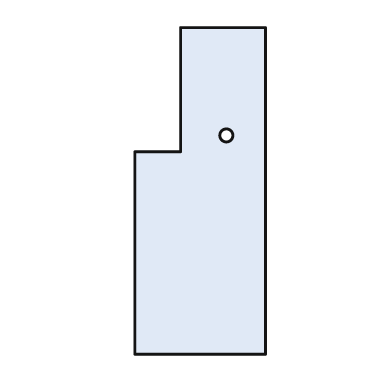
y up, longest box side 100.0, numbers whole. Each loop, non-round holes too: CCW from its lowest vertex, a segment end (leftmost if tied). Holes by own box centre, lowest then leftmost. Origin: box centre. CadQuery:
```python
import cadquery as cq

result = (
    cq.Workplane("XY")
    .moveTo(-20.0, -50.0)
    .lineTo(20.0, -50.0)
    .lineTo(20.0, 50.0)
    .lineTo(-6.0, 50.0)
    .lineTo(-6.0, 12.0)
    .lineTo(-20.0, 12.0)
    .close()
    .moveTo(8.0, 17.0)
    .circle(2.0)
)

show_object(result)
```